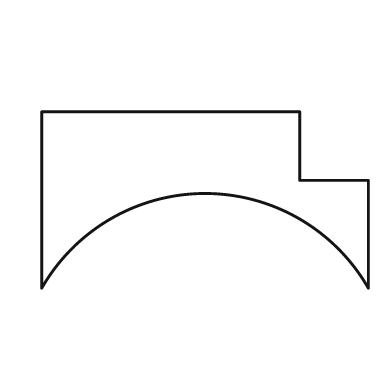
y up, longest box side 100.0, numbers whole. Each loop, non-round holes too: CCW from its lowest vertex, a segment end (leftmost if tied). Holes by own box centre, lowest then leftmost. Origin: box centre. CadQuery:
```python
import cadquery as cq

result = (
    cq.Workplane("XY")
    .moveTo(-50.0, -27.0)
    .threePointArc((0.0, 2.0), (50.0, -27.0))
    .lineTo(50.0, 6.0)
    .lineTo(29.0, 6.0)
    .lineTo(29.0, 27.0)
    .lineTo(-50.0, 27.0)
    .close()
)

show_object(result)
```